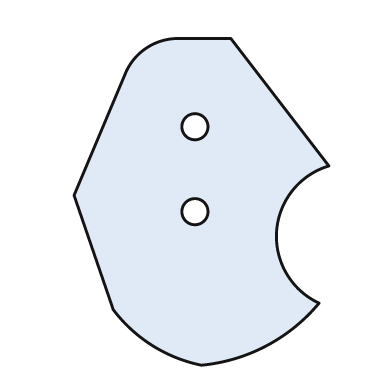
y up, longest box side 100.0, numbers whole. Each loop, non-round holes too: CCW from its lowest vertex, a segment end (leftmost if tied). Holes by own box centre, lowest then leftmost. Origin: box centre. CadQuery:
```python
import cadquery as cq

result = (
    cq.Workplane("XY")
    .moveTo(0.0, -50.0)
    .threePointArc((20.0, -44.0), (36.0, -31.0))
    .threePointArc((23.0, -9.0), (39.0, 11.0))
    .lineTo(9.0, 50.0)
    .lineTo(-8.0, 50.0)
    .threePointArc((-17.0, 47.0), (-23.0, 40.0))
    .lineTo(-39.0, 2.0)
    .lineTo(-27.0, -33.0)
    .threePointArc((-15.0, -44.0), (0.0, -50.0))
    .close()
    .moveTo(-2.0, -3.0)
    .circle(4.0)
    .moveTo(-2.0, 23.0)
    .circle(4.0)
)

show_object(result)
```